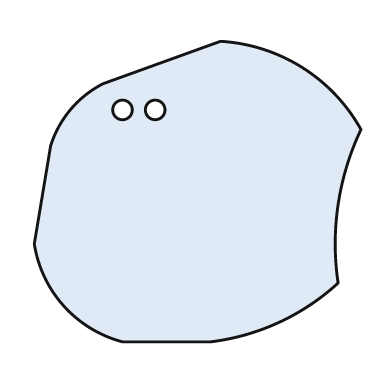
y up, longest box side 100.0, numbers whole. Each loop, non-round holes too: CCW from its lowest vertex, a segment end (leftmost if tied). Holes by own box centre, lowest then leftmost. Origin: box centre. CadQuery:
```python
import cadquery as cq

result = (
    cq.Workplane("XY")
    .moveTo(-23.0, -46.0)
    .lineTo(4.0, -46.0)
    .threePointArc((25.0, -40.0), (43.0, -28.0))
    .threePointArc((43.0, -4.0), (50.0, 19.0))
    .threePointArc((32.0, 38.0), (7.0, 46.0))
    .lineTo(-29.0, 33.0)
    .threePointArc((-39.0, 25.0), (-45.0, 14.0))
    .lineTo(-50.0, -16.0)
    .threePointArc((-41.0, -35.0), (-23.0, -46.0))
    .close()
    .moveTo(-23.0, 25.0)
    .circle(3.0)
    .moveTo(-13.0, 25.0)
    .circle(3.0)
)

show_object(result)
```